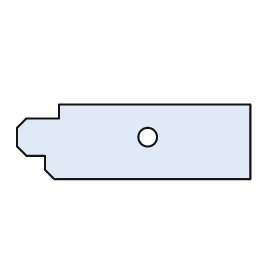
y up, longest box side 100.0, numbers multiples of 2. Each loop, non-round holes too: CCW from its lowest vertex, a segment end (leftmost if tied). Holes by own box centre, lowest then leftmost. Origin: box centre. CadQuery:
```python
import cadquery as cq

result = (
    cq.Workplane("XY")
    .moveTo(-34.0, -16.0)
    .lineTo(50.0, -16.0)
    .lineTo(50.0, 16.0)
    .lineTo(-32.0, 16.0)
    .lineTo(-32.0, 10.0)
    .lineTo(-46.0, 10.0)
    .lineTo(-50.0, 6.0)
    .lineTo(-50.0, -2.0)
    .lineTo(-46.0, -6.0)
    .lineTo(-38.0, -6.0)
    .lineTo(-38.0, -12.0)
    .close()
    .moveTo(6.0, 2.0)
    .circle(4.0)
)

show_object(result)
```